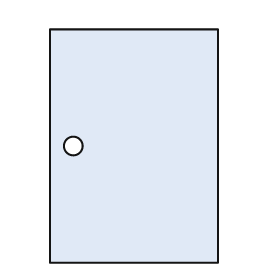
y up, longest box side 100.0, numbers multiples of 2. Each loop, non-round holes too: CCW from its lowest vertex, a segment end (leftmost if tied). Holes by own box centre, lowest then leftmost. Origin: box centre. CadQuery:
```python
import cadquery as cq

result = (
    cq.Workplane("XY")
    .moveTo(-36.0, -50.0)
    .lineTo(36.0, -50.0)
    .lineTo(36.0, 50.0)
    .lineTo(-36.0, 50.0)
    .close()
    .moveTo(-26.0, 0.0)
    .circle(4.0)
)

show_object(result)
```